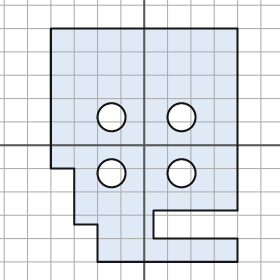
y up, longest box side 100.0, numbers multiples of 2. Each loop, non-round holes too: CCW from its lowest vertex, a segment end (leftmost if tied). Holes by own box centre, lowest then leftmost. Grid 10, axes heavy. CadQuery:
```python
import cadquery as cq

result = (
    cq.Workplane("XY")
    .moveTo(-20.0, -50.0)
    .lineTo(40.0, -50.0)
    .lineTo(40.0, -40.0)
    .lineTo(4.0, -40.0)
    .lineTo(4.0, -28.0)
    .lineTo(40.0, -28.0)
    .lineTo(40.0, 50.0)
    .lineTo(-40.0, 50.0)
    .lineTo(-40.0, -10.0)
    .lineTo(-30.0, -10.0)
    .lineTo(-30.0, -34.0)
    .lineTo(-20.0, -34.0)
    .close()
    .moveTo(-14.0, -12.0)
    .circle(6.0)
    .moveTo(16.0, -12.0)
    .circle(6.0)
    .moveTo(-14.0, 12.0)
    .circle(6.0)
    .moveTo(16.0, 12.0)
    .circle(6.0)
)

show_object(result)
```